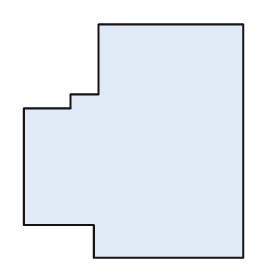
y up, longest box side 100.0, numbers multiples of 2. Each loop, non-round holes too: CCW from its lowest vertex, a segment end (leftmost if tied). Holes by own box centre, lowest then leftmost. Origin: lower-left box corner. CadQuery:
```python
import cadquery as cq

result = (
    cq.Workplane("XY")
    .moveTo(30.0, 0.0)
    .lineTo(94.0, 0.0)
    .lineTo(94.0, 100.0)
    .lineTo(32.0, 100.0)
    .lineTo(32.0, 70.0)
    .lineTo(20.0, 70.0)
    .lineTo(20.0, 64.0)
    .lineTo(0.0, 64.0)
    .lineTo(0.0, 14.0)
    .lineTo(30.0, 14.0)
    .close()
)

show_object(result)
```